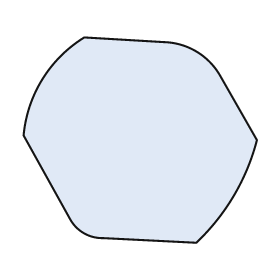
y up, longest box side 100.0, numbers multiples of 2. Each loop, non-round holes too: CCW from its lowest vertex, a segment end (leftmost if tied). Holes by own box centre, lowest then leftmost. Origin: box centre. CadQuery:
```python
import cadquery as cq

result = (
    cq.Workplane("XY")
    .moveTo(24.0, -44.0)
    .threePointArc((40.0, -24.0), (50.0, 0.0))
    .lineTo(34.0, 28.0)
    .threePointArc((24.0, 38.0), (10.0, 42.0))
    .lineTo(-24.0, 44.0)
    .threePointArc((-42.0, 26.0), (-50.0, 2.0))
    .lineTo(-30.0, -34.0)
    .threePointArc((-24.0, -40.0), (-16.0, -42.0))
    .close()
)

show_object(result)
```